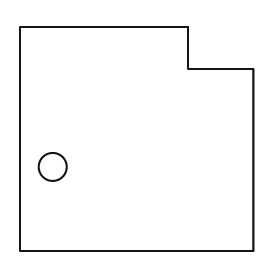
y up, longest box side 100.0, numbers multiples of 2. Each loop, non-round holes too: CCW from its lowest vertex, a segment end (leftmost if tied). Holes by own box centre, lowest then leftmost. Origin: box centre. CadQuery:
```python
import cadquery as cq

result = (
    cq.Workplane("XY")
    .moveTo(-50.0, -48.0)
    .lineTo(50.0, -48.0)
    .lineTo(50.0, 30.0)
    .lineTo(22.0, 30.0)
    .lineTo(22.0, 48.0)
    .lineTo(-50.0, 48.0)
    .close()
    .moveTo(-36.0, -12.0)
    .circle(6.0)
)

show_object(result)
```